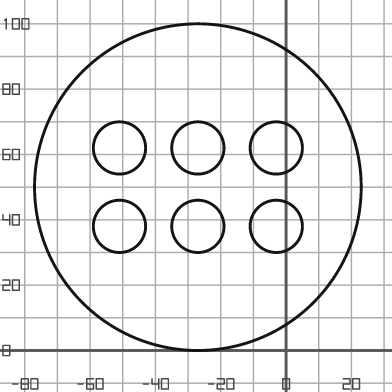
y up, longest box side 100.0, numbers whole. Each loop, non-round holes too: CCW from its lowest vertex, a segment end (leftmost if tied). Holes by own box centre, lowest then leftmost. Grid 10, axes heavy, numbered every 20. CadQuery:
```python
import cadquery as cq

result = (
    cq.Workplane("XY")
    .moveTo(-27.0, 50.0)
    .circle(50.0)
    .moveTo(-51.0, 38.0)
    .circle(8.0)
    .moveTo(-27.0, 38.0)
    .circle(8.0)
    .moveTo(-3.0, 38.0)
    .circle(8.0)
    .moveTo(-51.0, 62.0)
    .circle(8.0)
    .moveTo(-27.0, 62.0)
    .circle(8.0)
    .moveTo(-3.0, 62.0)
    .circle(8.0)
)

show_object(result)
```